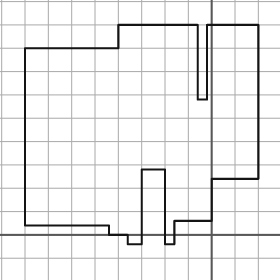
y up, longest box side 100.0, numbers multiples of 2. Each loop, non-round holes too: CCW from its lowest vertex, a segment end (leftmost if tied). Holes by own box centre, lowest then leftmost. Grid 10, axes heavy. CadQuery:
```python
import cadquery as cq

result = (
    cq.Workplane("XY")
    .moveTo(-36.0, -4.0)
    .lineTo(-30.0, -4.0)
    .lineTo(-30.0, 28.0)
    .lineTo(-20.0, 28.0)
    .lineTo(-20.0, -4.0)
    .lineTo(-16.0, -4.0)
    .lineTo(-16.0, 6.0)
    .lineTo(0.0, 6.0)
    .lineTo(0.0, 24.0)
    .lineTo(20.0, 24.0)
    .lineTo(20.0, 90.0)
    .lineTo(-2.0, 90.0)
    .lineTo(-2.0, 58.0)
    .lineTo(-6.0, 58.0)
    .lineTo(-6.0, 90.0)
    .lineTo(-40.0, 90.0)
    .lineTo(-40.0, 80.0)
    .lineTo(-80.0, 80.0)
    .lineTo(-80.0, 4.0)
    .lineTo(-44.0, 4.0)
    .lineTo(-44.0, 0.0)
    .lineTo(-36.0, 0.0)
    .close()
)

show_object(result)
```